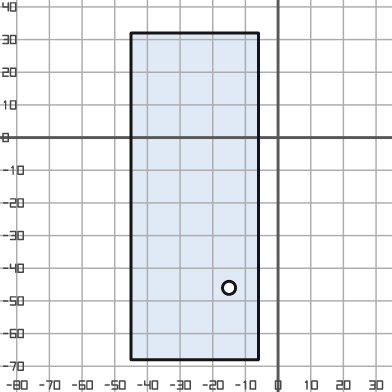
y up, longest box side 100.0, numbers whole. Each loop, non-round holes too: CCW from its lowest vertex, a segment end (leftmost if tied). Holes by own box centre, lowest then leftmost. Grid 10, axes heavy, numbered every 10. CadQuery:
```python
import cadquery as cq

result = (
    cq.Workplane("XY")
    .moveTo(-45.0, -68.0)
    .lineTo(-6.0, -68.0)
    .lineTo(-6.0, 32.0)
    .lineTo(-45.0, 32.0)
    .close()
    .moveTo(-15.0, -46.0)
    .circle(2.0)
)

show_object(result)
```